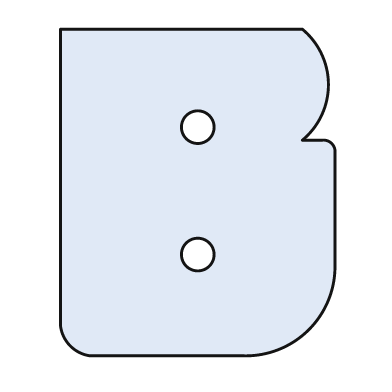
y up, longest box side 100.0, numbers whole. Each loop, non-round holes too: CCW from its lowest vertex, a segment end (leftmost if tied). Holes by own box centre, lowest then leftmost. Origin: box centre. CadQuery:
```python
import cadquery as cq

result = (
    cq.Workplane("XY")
    .moveTo(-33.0, -50.0)
    .lineTo(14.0, -50.0)
    .threePointArc((34.0, -42.0), (42.0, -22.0))
    .lineTo(42.0, 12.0)
    .threePointArc((41.0, 15.0), (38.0, 16.0))
    .lineTo(32.0, 16.0)
    .threePointArc((40.0, 33.0), (32.0, 50.0))
    .lineTo(-42.0, 50.0)
    .lineTo(-42.0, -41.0)
    .threePointArc((-39.0, -47.0), (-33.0, -50.0))
    .close()
    .moveTo(0.0, -19.0)
    .circle(5.0)
    .moveTo(0.0, 20.0)
    .circle(5.0)
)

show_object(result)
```